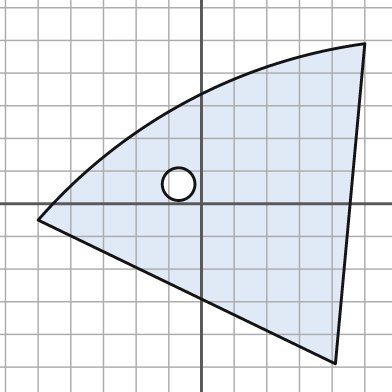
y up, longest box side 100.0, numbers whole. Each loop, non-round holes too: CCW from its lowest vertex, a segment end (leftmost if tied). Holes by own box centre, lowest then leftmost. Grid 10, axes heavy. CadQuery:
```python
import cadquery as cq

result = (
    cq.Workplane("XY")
    .moveTo(41.0, -49.0)
    .lineTo(50.0, 49.0)
    .threePointArc((-5.0, 31.0), (-50.0, -5.0))
    .close()
    .moveTo(-7.0, 6.0)
    .circle(5.0)
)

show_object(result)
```